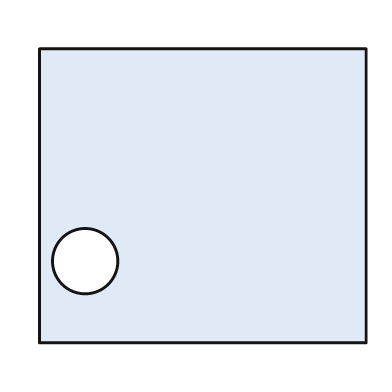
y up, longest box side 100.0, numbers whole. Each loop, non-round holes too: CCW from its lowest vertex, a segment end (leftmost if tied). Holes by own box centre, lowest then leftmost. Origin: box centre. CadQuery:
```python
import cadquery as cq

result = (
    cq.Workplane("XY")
    .moveTo(-50.0, -45.0)
    .lineTo(50.0, -45.0)
    .lineTo(50.0, 45.0)
    .lineTo(-50.0, 45.0)
    .close()
    .moveTo(-36.0, -20.0)
    .circle(10.0)
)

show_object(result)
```